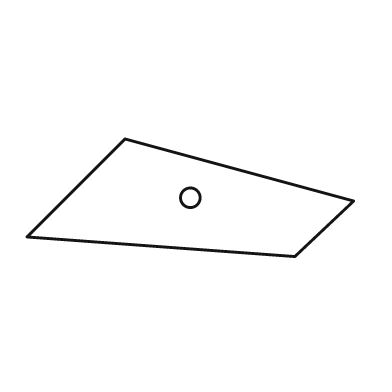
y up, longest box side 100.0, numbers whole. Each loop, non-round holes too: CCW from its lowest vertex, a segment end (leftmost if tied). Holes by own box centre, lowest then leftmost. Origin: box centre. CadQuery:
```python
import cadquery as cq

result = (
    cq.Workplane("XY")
    .moveTo(32.0, -18.0)
    .lineTo(50.0, -1.0)
    .lineTo(-20.0, 18.0)
    .lineTo(-50.0, -12.0)
    .close()
    .moveTo(0.0, 0.0)
    .circle(3.0)
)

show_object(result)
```